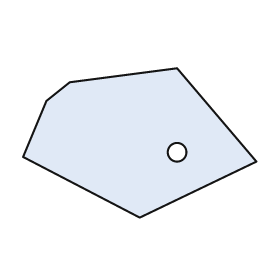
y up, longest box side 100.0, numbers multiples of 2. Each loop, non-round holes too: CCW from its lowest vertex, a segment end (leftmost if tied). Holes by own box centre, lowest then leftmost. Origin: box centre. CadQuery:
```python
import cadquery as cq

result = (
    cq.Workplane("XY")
    .moveTo(0.0, -32.0)
    .lineTo(50.0, -8.0)
    .lineTo(16.0, 32.0)
    .lineTo(-30.0, 26.0)
    .lineTo(-40.0, 18.0)
    .lineTo(-50.0, -6.0)
    .close()
    .moveTo(16.0, -4.0)
    .circle(4.0)
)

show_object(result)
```